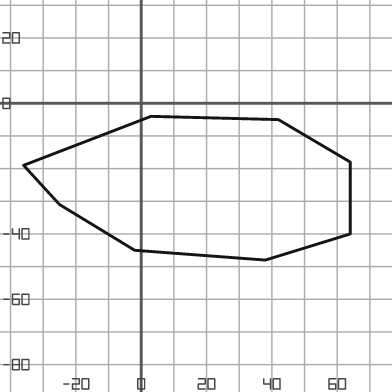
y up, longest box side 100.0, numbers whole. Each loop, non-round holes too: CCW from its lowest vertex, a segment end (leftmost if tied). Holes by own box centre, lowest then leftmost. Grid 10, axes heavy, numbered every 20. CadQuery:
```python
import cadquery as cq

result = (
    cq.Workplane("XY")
    .moveTo(38.0, -48.0)
    .lineTo(64.0, -40.0)
    .lineTo(64.0, -18.0)
    .lineTo(42.0, -5.0)
    .lineTo(3.0, -4.0)
    .lineTo(-36.0, -19.0)
    .lineTo(-25.0, -31.0)
    .lineTo(-2.0, -45.0)
    .close()
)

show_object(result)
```